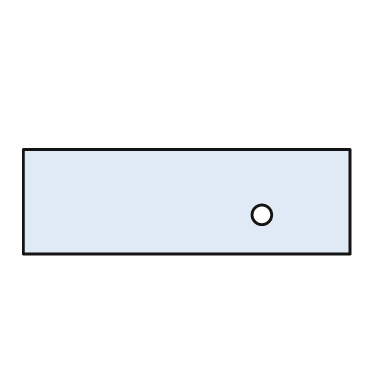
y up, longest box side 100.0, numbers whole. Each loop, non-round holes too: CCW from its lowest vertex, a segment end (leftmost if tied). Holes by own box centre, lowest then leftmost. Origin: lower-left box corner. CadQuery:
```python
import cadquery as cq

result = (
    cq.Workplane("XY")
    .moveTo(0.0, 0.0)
    .lineTo(100.0, 0.0)
    .lineTo(100.0, 32.0)
    .lineTo(0.0, 32.0)
    .close()
    .moveTo(73.0, 12.0)
    .circle(3.0)
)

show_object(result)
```